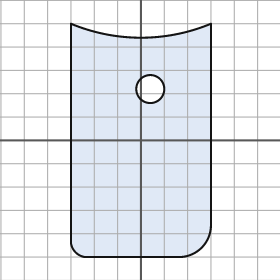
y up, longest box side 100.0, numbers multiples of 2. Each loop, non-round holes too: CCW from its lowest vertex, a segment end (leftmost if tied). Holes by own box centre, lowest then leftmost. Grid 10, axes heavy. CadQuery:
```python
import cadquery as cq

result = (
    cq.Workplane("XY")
    .moveTo(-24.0, -50.0)
    .lineTo(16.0, -50.0)
    .threePointArc((26.0, -46.0), (30.0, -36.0))
    .lineTo(30.0, 50.0)
    .threePointArc((0.0, 44.0), (-30.0, 50.0))
    .lineTo(-30.0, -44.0)
    .threePointArc((-28.0, -48.0), (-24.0, -50.0))
    .close()
    .moveTo(4.0, 22.0)
    .circle(6.0)
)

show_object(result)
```